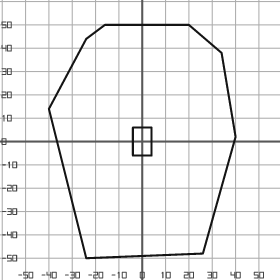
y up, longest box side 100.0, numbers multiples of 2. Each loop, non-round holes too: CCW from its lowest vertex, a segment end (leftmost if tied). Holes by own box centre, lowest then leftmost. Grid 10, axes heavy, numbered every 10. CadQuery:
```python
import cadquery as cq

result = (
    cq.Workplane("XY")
    .moveTo(-24.0, -50.0)
    .lineTo(26.0, -48.0)
    .lineTo(40.0, 2.0)
    .lineTo(34.0, 38.0)
    .lineTo(20.0, 50.0)
    .lineTo(-16.0, 50.0)
    .lineTo(-24.0, 44.0)
    .lineTo(-40.0, 14.0)
    .close()
    .moveTo(-4.0, -6.0)
    .lineTo(4.0, -6.0)
    .lineTo(4.0, 6.0)
    .lineTo(-4.0, 6.0)
    .close()
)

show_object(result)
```